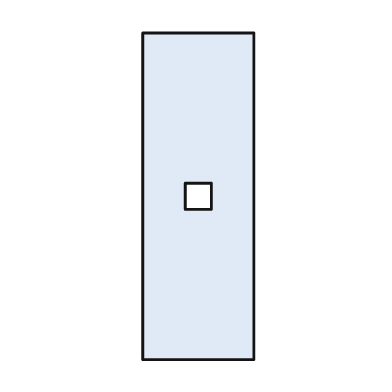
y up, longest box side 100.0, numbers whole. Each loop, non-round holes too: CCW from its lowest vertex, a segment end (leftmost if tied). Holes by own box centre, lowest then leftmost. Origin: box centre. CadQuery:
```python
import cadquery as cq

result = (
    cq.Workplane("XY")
    .moveTo(-17.0, -50.0)
    .lineTo(17.0, -50.0)
    .lineTo(17.0, 50.0)
    .lineTo(-17.0, 50.0)
    .close()
    .moveTo(-4.0, -4.0)
    .lineTo(4.0, -4.0)
    .lineTo(4.0, 4.0)
    .lineTo(-4.0, 4.0)
    .close()
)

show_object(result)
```